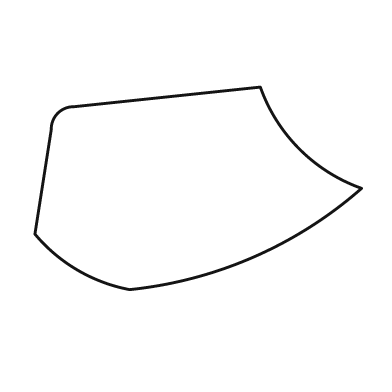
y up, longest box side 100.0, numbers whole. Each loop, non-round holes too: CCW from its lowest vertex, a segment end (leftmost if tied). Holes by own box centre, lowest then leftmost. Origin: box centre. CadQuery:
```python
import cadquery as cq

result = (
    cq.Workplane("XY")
    .moveTo(-21.0, -31.0)
    .threePointArc((17.0, -21.0), (50.0, 0.0))
    .threePointArc((31.0, 12.0), (19.0, 31.0))
    .lineTo(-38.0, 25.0)
    .threePointArc((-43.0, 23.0), (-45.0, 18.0))
    .lineTo(-50.0, -14.0)
    .threePointArc((-37.0, -25.0), (-21.0, -31.0))
    .close()
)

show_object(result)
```